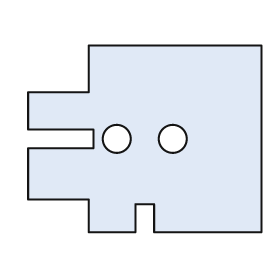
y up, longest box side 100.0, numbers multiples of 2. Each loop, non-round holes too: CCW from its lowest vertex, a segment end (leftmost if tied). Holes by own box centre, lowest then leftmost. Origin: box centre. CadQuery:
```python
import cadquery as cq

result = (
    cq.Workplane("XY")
    .moveTo(-24.0, -40.0)
    .lineTo(-4.0, -40.0)
    .lineTo(-4.0, -28.0)
    .lineTo(4.0, -28.0)
    .lineTo(4.0, -40.0)
    .lineTo(50.0, -40.0)
    .lineTo(50.0, 40.0)
    .lineTo(-24.0, 40.0)
    .lineTo(-24.0, 20.0)
    .lineTo(-50.0, 20.0)
    .lineTo(-50.0, 4.0)
    .lineTo(-22.0, 4.0)
    .lineTo(-22.0, -4.0)
    .lineTo(-50.0, -4.0)
    .lineTo(-50.0, -26.0)
    .lineTo(-24.0, -26.0)
    .close()
    .moveTo(-12.0, 0.0)
    .circle(6.0)
    .moveTo(12.0, 0.0)
    .circle(6.0)
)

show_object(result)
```